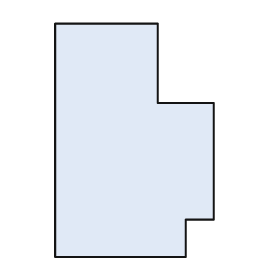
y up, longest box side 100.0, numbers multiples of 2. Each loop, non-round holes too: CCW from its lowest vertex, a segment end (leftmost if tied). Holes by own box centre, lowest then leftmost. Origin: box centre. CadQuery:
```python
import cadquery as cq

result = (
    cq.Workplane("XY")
    .moveTo(-34.0, -50.0)
    .lineTo(22.0, -50.0)
    .lineTo(22.0, -34.0)
    .lineTo(34.0, -34.0)
    .lineTo(34.0, 16.0)
    .lineTo(10.0, 16.0)
    .lineTo(10.0, 50.0)
    .lineTo(-34.0, 50.0)
    .close()
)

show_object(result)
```